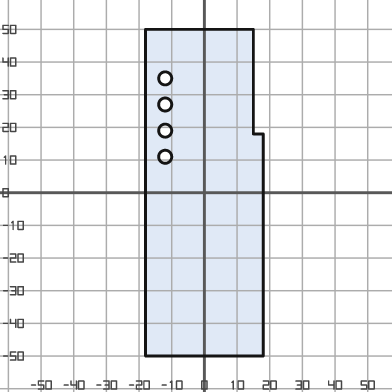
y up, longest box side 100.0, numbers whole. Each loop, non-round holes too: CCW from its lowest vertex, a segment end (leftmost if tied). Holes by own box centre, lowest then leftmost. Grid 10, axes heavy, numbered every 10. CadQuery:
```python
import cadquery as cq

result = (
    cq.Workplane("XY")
    .moveTo(-18.0, -50.0)
    .lineTo(18.0, -50.0)
    .lineTo(18.0, 18.0)
    .lineTo(15.0, 18.0)
    .lineTo(15.0, 50.0)
    .lineTo(-18.0, 50.0)
    .close()
    .moveTo(-12.0, 11.0)
    .circle(2.0)
    .moveTo(-12.0, 19.0)
    .circle(2.0)
    .moveTo(-12.0, 27.0)
    .circle(2.0)
    .moveTo(-12.0, 35.0)
    .circle(2.0)
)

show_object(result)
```